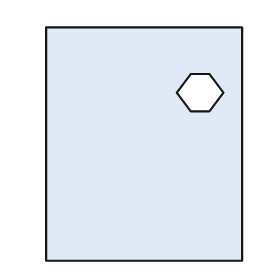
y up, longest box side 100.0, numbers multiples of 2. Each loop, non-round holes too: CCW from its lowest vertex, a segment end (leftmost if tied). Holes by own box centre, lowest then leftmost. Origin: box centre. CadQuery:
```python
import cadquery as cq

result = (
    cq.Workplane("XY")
    .moveTo(-42.0, -50.0)
    .lineTo(42.0, -50.0)
    .lineTo(42.0, 50.0)
    .lineTo(-42.0, 50.0)
    .close()
    .moveTo(20.0, 14.0)
    .lineTo(28.0, 14.0)
    .lineTo(34.0, 22.0)
    .lineTo(28.0, 30.0)
    .lineTo(20.0, 30.0)
    .lineTo(14.0, 22.0)
    .close()
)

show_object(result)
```